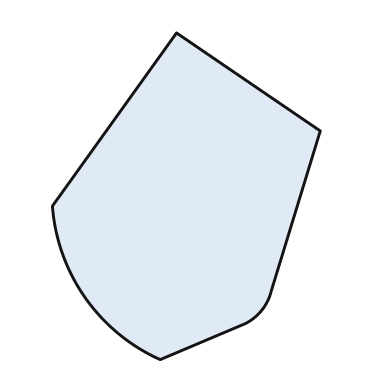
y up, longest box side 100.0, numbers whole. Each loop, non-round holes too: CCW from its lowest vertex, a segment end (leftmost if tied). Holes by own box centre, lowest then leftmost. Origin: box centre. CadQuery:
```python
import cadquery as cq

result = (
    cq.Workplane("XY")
    .moveTo(-8.0, -50.0)
    .lineTo(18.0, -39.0)
    .threePointArc((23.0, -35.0), (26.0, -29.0))
    .lineTo(41.0, 20.0)
    .lineTo(-3.0, 50.0)
    .lineTo(-41.0, -3.0)
    .threePointArc((-31.0, -31.0), (-8.0, -50.0))
    .close()
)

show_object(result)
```